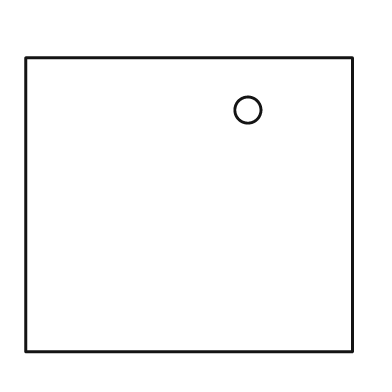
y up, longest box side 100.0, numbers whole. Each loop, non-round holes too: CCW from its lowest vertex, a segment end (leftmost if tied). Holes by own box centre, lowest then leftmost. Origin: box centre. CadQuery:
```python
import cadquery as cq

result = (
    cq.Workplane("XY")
    .moveTo(-50.0, -45.0)
    .lineTo(50.0, -45.0)
    .lineTo(50.0, 45.0)
    .lineTo(-50.0, 45.0)
    .close()
    .moveTo(18.0, 29.0)
    .circle(4.0)
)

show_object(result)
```